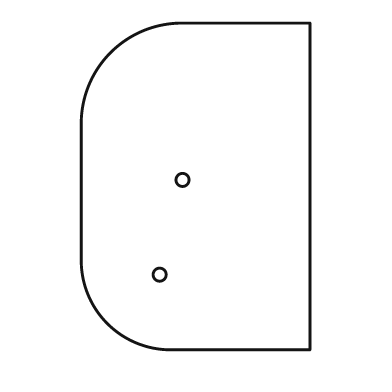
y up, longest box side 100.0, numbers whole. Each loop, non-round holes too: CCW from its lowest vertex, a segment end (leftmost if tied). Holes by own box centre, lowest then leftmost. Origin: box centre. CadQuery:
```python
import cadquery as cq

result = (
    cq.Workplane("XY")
    .moveTo(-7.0, -50.0)
    .lineTo(35.0, -50.0)
    .lineTo(35.0, 50.0)
    .lineTo(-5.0, 50.0)
    .threePointArc((-26.0, 41.0), (-35.0, 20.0))
    .lineTo(-35.0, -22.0)
    .threePointArc((-27.0, -42.0), (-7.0, -50.0))
    .close()
    .moveTo(-11.0, -27.0)
    .circle(2.0)
    .moveTo(-4.0, 2.0)
    .circle(2.0)
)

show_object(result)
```